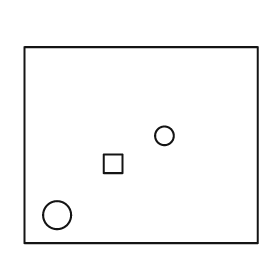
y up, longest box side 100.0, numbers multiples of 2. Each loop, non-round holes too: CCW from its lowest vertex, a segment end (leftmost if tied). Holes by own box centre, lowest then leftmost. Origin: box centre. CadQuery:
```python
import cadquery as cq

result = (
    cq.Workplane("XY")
    .moveTo(-50.0, -42.0)
    .lineTo(50.0, -42.0)
    .lineTo(50.0, 42.0)
    .lineTo(-50.0, 42.0)
    .close()
    .moveTo(-36.0, -30.0)
    .circle(6.0)
    .moveTo(-16.0, -12.0)
    .lineTo(-8.0, -12.0)
    .lineTo(-8.0, -4.0)
    .lineTo(-16.0, -4.0)
    .close()
    .moveTo(10.0, 4.0)
    .circle(4.0)
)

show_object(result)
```